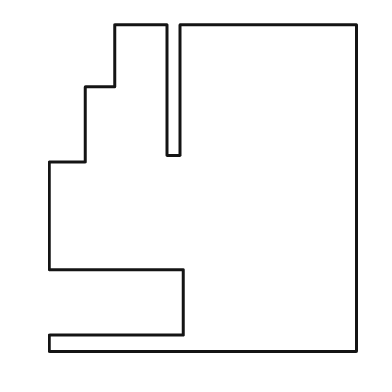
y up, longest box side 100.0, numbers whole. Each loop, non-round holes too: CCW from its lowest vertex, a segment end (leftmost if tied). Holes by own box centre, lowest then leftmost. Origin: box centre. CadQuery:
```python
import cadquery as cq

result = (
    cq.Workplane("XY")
    .moveTo(-47.0, -50.0)
    .lineTo(47.0, -50.0)
    .lineTo(47.0, 50.0)
    .lineTo(-7.0, 50.0)
    .lineTo(-7.0, 10.0)
    .lineTo(-11.0, 10.0)
    .lineTo(-11.0, 50.0)
    .lineTo(-27.0, 50.0)
    .lineTo(-27.0, 31.0)
    .lineTo(-36.0, 31.0)
    .lineTo(-36.0, 8.0)
    .lineTo(-47.0, 8.0)
    .lineTo(-47.0, -25.0)
    .lineTo(-6.0, -25.0)
    .lineTo(-6.0, -45.0)
    .lineTo(-47.0, -45.0)
    .close()
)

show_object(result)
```